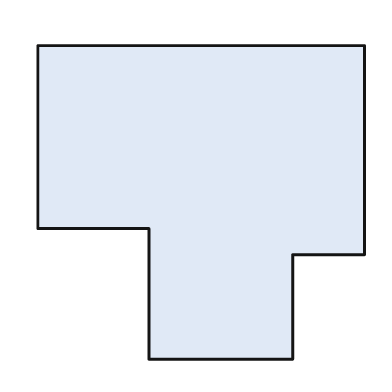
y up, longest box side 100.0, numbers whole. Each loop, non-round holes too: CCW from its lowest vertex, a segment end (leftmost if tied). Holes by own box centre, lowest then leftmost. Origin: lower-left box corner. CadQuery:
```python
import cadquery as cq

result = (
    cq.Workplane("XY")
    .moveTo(34.0, 0.0)
    .lineTo(78.0, 0.0)
    .lineTo(78.0, 32.0)
    .lineTo(100.0, 32.0)
    .lineTo(100.0, 96.0)
    .lineTo(0.0, 96.0)
    .lineTo(0.0, 40.0)
    .lineTo(34.0, 40.0)
    .close()
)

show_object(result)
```